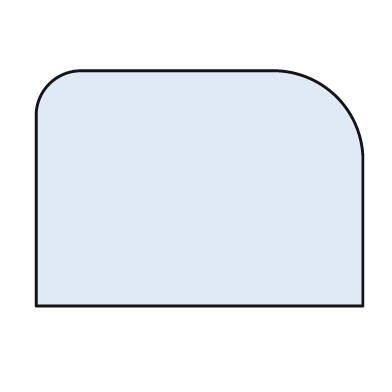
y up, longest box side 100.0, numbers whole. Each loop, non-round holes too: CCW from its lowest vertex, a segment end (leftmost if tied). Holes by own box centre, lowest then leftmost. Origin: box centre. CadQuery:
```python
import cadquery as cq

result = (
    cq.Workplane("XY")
    .moveTo(-50.0, -36.0)
    .lineTo(50.0, -36.0)
    .lineTo(50.0, 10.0)
    .threePointArc((42.0, 28.0), (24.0, 36.0))
    .lineTo(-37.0, 36.0)
    .threePointArc((-46.0, 32.0), (-50.0, 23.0))
    .close()
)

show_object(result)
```